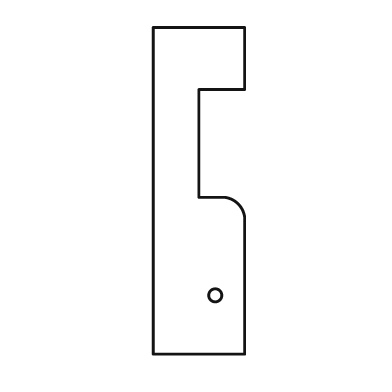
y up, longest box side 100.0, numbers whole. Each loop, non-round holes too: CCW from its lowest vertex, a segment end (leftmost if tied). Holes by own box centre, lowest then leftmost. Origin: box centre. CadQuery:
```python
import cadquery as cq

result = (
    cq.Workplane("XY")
    .moveTo(-14.0, -50.0)
    .lineTo(14.0, -50.0)
    .lineTo(14.0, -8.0)
    .threePointArc((12.0, -4.0), (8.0, -2.0))
    .lineTo(0.0, -2.0)
    .lineTo(0.0, 31.0)
    .lineTo(14.0, 31.0)
    .lineTo(14.0, 50.0)
    .lineTo(-14.0, 50.0)
    .close()
    .moveTo(5.0, -32.0)
    .circle(2.0)
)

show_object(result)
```